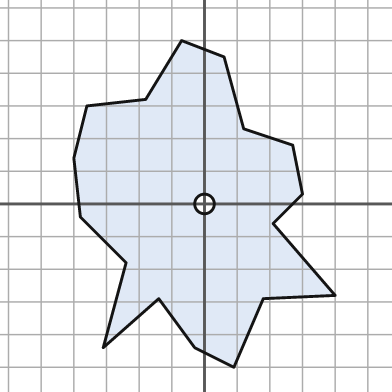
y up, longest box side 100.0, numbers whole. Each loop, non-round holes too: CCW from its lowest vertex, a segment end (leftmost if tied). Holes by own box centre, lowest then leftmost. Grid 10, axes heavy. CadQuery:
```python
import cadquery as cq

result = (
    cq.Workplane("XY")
    .moveTo(9.0, -50.0)
    .lineTo(18.0, -29.0)
    .lineTo(40.0, -28.0)
    .lineTo(21.0, -6.0)
    .lineTo(30.0, 3.0)
    .lineTo(27.0, 18.0)
    .lineTo(12.0, 23.0)
    .lineTo(6.0, 45.0)
    .lineTo(-7.0, 50.0)
    .lineTo(-18.0, 32.0)
    .lineTo(-36.0, 30.0)
    .lineTo(-40.0, 14.0)
    .lineTo(-38.0, -4.0)
    .lineTo(-24.0, -18.0)
    .lineTo(-31.0, -44.0)
    .lineTo(-14.0, -29.0)
    .lineTo(-3.0, -44.0)
    .close()
    .moveTo(0.0, 0.0)
    .circle(3.0)
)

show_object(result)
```